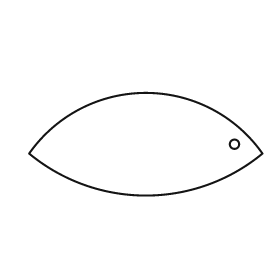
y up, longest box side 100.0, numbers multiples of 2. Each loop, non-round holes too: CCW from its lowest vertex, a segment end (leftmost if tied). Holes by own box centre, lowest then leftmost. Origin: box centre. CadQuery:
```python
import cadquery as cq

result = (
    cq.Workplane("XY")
    .moveTo(-50.0, -4.0)
    .threePointArc((0.0, -22.0), (50.0, -4.0))
    .threePointArc((0.0, 22.0), (-50.0, -4.0))
    .close()
    .moveTo(38.0, 0.0)
    .circle(2.0)
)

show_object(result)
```